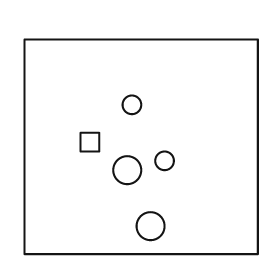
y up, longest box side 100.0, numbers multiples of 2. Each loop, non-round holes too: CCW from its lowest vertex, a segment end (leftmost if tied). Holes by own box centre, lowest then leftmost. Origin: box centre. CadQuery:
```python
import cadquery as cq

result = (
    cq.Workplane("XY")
    .moveTo(-50.0, -46.0)
    .lineTo(50.0, -46.0)
    .lineTo(50.0, 46.0)
    .lineTo(-50.0, 46.0)
    .close()
    .moveTo(4.0, -34.0)
    .circle(6.0)
    .moveTo(-6.0, -10.0)
    .circle(6.0)
    .moveTo(10.0, -6.0)
    .circle(4.0)
    .moveTo(-26.0, -2.0)
    .lineTo(-18.0, -2.0)
    .lineTo(-18.0, 6.0)
    .lineTo(-26.0, 6.0)
    .close()
    .moveTo(-4.0, 18.0)
    .circle(4.0)
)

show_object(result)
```